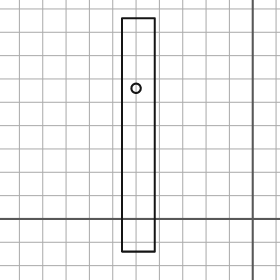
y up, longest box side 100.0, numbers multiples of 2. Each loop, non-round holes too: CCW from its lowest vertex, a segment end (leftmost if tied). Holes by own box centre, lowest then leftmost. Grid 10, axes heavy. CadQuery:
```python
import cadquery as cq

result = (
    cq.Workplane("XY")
    .moveTo(-56.0, -14.0)
    .lineTo(-42.0, -14.0)
    .lineTo(-42.0, 86.0)
    .lineTo(-56.0, 86.0)
    .close()
    .moveTo(-50.0, 56.0)
    .circle(2.0)
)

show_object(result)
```